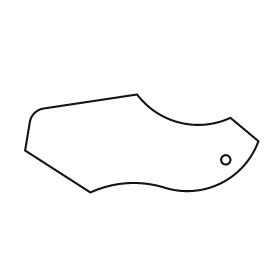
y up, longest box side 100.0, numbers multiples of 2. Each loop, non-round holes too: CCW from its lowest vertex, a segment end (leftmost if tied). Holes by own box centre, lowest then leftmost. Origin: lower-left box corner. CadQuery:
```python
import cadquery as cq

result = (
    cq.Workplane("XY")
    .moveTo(28.0, 0.0)
    .threePointArc((44.0, 4.0), (60.0, 2.0))
    .threePointArc((84.0, 4.0), (100.0, 22.0))
    .lineTo(88.0, 32.0)
    .threePointArc((66.0, 30.0), (48.0, 42.0))
    .lineTo(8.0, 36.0)
    .threePointArc((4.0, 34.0), (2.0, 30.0))
    .lineTo(0.0, 18.0)
    .close()
    .moveTo(86.0, 14.0)
    .circle(2.0)
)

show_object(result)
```